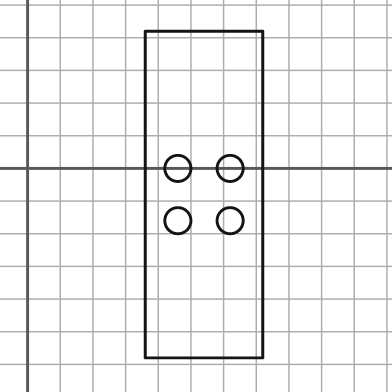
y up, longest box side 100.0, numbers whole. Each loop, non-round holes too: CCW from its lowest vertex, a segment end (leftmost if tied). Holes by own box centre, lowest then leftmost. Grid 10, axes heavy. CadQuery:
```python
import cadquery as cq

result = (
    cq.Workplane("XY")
    .moveTo(36.0, -58.0)
    .lineTo(72.0, -58.0)
    .lineTo(72.0, 42.0)
    .lineTo(36.0, 42.0)
    .close()
    .moveTo(46.0, -16.0)
    .circle(4.0)
    .moveTo(62.0, -16.0)
    .circle(4.0)
    .moveTo(46.0, 0.0)
    .circle(4.0)
    .moveTo(62.0, 0.0)
    .circle(4.0)
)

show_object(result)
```